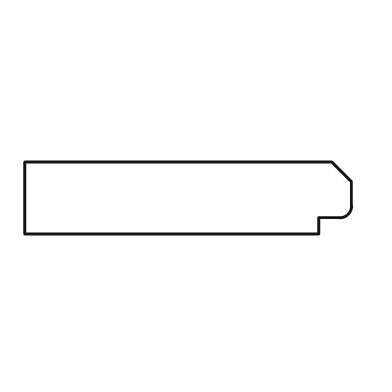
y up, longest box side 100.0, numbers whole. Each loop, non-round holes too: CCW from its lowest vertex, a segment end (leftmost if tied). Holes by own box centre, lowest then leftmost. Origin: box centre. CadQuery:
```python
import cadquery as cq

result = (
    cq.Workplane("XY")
    .moveTo(-50.0, -11.0)
    .lineTo(40.0, -11.0)
    .lineTo(40.0, -6.0)
    .lineTo(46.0, -6.0)
    .threePointArc((49.0, -5.0), (50.0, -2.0))
    .lineTo(50.0, 5.0)
    .lineTo(44.0, 11.0)
    .lineTo(-50.0, 11.0)
    .close()
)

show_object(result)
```